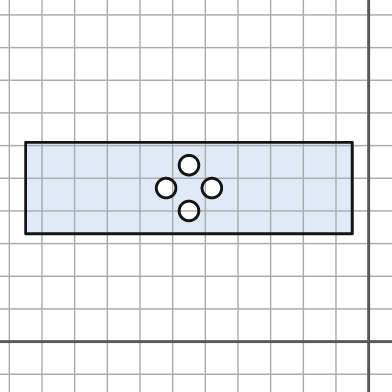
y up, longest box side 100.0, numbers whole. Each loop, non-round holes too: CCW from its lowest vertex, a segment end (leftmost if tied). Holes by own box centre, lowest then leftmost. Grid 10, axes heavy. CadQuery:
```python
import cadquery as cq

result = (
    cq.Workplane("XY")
    .moveTo(-105.0, 33.0)
    .lineTo(-5.0, 33.0)
    .lineTo(-5.0, 61.0)
    .lineTo(-105.0, 61.0)
    .close()
    .moveTo(-55.0, 40.0)
    .circle(3.0)
    .moveTo(-62.0, 47.0)
    .circle(3.0)
    .moveTo(-48.0, 47.0)
    .circle(3.0)
    .moveTo(-55.0, 54.0)
    .circle(3.0)
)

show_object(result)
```